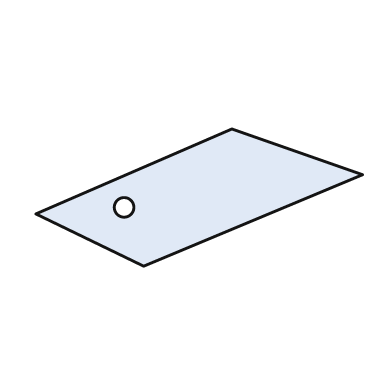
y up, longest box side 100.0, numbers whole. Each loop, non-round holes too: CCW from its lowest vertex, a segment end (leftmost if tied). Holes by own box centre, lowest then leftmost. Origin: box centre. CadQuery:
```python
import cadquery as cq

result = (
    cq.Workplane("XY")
    .moveTo(-17.0, -21.0)
    .lineTo(50.0, 7.0)
    .lineTo(10.0, 21.0)
    .lineTo(-50.0, -5.0)
    .close()
    .moveTo(-23.0, -3.0)
    .circle(3.0)
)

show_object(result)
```